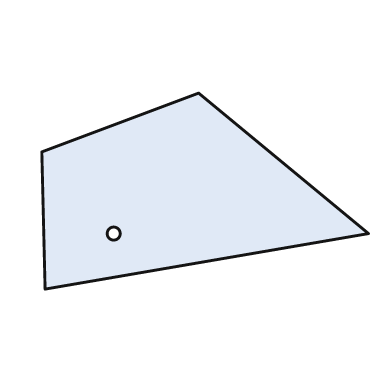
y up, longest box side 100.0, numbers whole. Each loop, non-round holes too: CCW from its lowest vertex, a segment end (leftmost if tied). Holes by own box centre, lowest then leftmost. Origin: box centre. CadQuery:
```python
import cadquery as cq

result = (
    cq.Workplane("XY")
    .moveTo(-49.0, -30.0)
    .lineTo(50.0, -13.0)
    .lineTo(-2.0, 30.0)
    .lineTo(-50.0, 12.0)
    .close()
    .moveTo(-28.0, -13.0)
    .circle(2.0)
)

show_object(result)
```